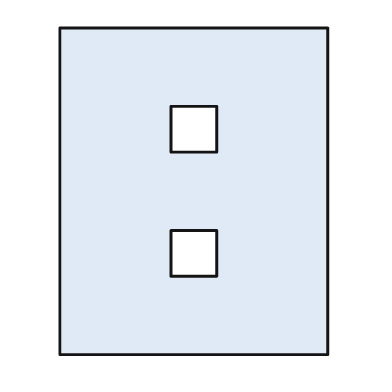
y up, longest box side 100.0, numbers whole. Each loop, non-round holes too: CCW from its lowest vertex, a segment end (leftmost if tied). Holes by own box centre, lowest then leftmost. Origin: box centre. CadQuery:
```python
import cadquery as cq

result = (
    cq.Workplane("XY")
    .moveTo(-41.0, -50.0)
    .lineTo(41.0, -50.0)
    .lineTo(41.0, 50.0)
    .lineTo(-41.0, 50.0)
    .close()
    .moveTo(-7.0, -26.0)
    .lineTo(7.0, -26.0)
    .lineTo(7.0, -12.0)
    .lineTo(-7.0, -12.0)
    .close()
    .moveTo(-7.0, 12.0)
    .lineTo(7.0, 12.0)
    .lineTo(7.0, 26.0)
    .lineTo(-7.0, 26.0)
    .close()
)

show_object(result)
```